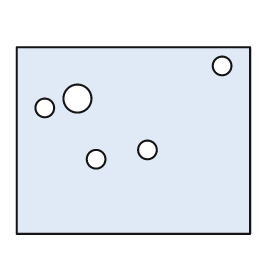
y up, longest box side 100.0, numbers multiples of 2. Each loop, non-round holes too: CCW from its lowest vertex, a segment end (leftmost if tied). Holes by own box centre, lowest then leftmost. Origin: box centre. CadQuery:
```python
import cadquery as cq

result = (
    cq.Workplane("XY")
    .moveTo(-50.0, -40.0)
    .lineTo(50.0, -40.0)
    .lineTo(50.0, 40.0)
    .lineTo(-50.0, 40.0)
    .close()
    .moveTo(-16.0, -8.0)
    .circle(4.0)
    .moveTo(6.0, -4.0)
    .circle(4.0)
    .moveTo(-38.0, 14.0)
    .circle(4.0)
    .moveTo(-24.0, 18.0)
    .circle(6.0)
    .moveTo(38.0, 32.0)
    .circle(4.0)
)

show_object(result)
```